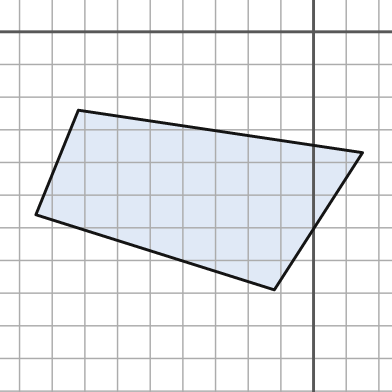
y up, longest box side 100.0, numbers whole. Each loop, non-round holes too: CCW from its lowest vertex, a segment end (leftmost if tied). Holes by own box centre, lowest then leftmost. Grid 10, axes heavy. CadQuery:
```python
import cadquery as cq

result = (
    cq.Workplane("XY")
    .moveTo(-12.0, -79.0)
    .lineTo(15.0, -37.0)
    .lineTo(-72.0, -24.0)
    .lineTo(-85.0, -56.0)
    .close()
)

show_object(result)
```